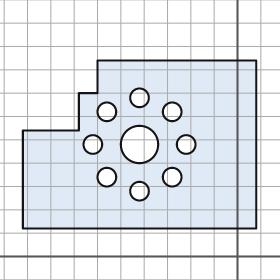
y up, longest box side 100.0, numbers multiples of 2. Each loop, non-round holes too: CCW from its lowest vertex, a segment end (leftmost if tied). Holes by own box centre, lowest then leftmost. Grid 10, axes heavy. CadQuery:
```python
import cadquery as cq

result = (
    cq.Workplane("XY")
    .moveTo(-92.0, 12.0)
    .lineTo(8.0, 12.0)
    .lineTo(8.0, 84.0)
    .lineTo(-60.0, 84.0)
    .lineTo(-60.0, 70.0)
    .lineTo(-68.0, 70.0)
    .lineTo(-68.0, 54.0)
    .lineTo(-92.0, 54.0)
    .close()
    .moveTo(-42.0, 28.0)
    .circle(4.0)
    .moveTo(-56.0, 34.0)
    .circle(4.0)
    .moveTo(-28.0, 34.0)
    .circle(4.0)
    .moveTo(-62.0, 48.0)
    .circle(4.0)
    .moveTo(-42.0, 48.0)
    .circle(8.0)
    .moveTo(-22.0, 48.0)
    .circle(4.0)
    .moveTo(-56.0, 62.0)
    .circle(4.0)
    .moveTo(-28.0, 62.0)
    .circle(4.0)
    .moveTo(-42.0, 68.0)
    .circle(4.0)
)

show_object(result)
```